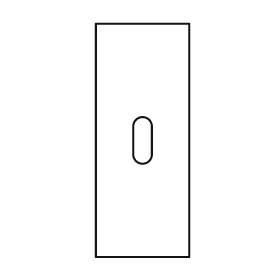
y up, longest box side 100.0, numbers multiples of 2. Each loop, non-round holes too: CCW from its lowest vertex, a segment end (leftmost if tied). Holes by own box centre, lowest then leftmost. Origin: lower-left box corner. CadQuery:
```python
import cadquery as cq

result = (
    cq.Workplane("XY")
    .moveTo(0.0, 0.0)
    .lineTo(40.0, 0.0)
    .lineTo(40.0, 100.0)
    .lineTo(0.0, 100.0)
    .close()
    .moveTo(16.0, 44.0)
    .threePointArc((20.0, 40.0), (24.0, 44.0))
    .lineTo(24.0, 56.0)
    .threePointArc((20.0, 60.0), (16.0, 56.0))
    .close()
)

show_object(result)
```